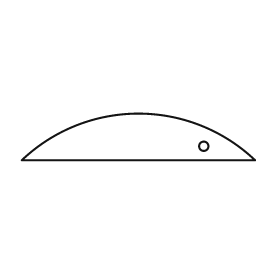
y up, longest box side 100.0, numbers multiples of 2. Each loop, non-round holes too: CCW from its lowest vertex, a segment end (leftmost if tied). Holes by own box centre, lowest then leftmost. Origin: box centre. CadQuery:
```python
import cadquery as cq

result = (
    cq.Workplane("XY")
    .moveTo(-50.0, -10.0)
    .lineTo(50.0, -10.0)
    .threePointArc((0.0, 10.0), (-50.0, -10.0))
    .close()
    .moveTo(28.0, -4.0)
    .circle(2.0)
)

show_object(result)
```